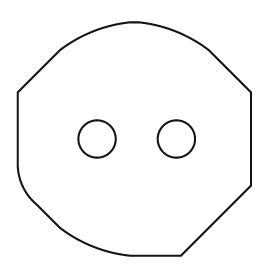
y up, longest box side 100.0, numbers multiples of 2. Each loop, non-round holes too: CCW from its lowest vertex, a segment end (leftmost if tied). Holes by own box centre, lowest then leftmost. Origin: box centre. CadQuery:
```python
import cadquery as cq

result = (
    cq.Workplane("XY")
    .moveTo(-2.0, -50.0)
    .lineTo(20.0, -50.0)
    .lineTo(50.0, -20.0)
    .lineTo(50.0, 20.0)
    .lineTo(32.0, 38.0)
    .threePointArc((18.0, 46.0), (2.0, 50.0))
    .lineTo(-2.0, 50.0)
    .threePointArc((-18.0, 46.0), (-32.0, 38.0))
    .lineTo(-50.0, 20.0)
    .lineTo(-50.0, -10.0)
    .threePointArc((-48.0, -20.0), (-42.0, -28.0))
    .lineTo(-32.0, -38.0)
    .threePointArc((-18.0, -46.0), (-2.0, -50.0))
    .close()
    .moveTo(-16.0, 0.0)
    .circle(8.0)
    .moveTo(18.0, 0.0)
    .circle(8.0)
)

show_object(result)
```